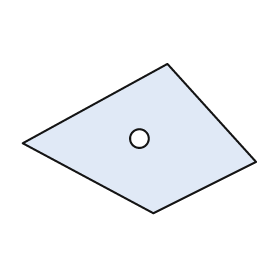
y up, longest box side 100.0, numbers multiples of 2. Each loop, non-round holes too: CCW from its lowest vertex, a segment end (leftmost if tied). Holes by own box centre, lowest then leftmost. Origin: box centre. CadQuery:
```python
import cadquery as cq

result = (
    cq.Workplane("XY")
    .moveTo(6.0, -32.0)
    .lineTo(50.0, -10.0)
    .lineTo(12.0, 32.0)
    .lineTo(-50.0, -2.0)
    .close()
    .moveTo(0.0, 0.0)
    .circle(4.0)
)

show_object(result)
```